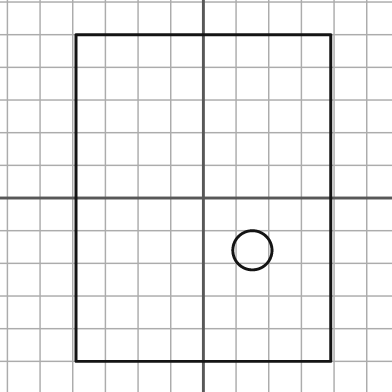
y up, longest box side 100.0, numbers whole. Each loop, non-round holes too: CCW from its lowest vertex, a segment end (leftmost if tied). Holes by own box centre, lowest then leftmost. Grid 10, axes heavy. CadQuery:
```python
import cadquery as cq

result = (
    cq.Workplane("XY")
    .moveTo(-39.0, -50.0)
    .lineTo(39.0, -50.0)
    .lineTo(39.0, 50.0)
    .lineTo(-39.0, 50.0)
    .close()
    .moveTo(15.0, -16.0)
    .circle(6.0)
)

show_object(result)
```